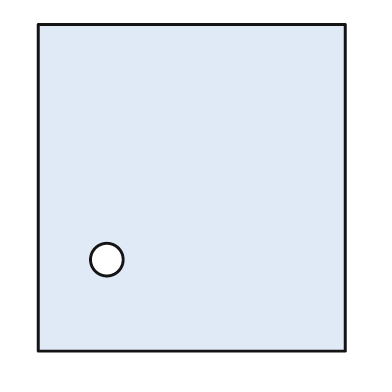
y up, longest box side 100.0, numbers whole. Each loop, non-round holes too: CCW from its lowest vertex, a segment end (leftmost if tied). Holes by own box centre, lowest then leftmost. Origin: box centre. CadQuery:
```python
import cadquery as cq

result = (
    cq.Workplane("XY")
    .moveTo(-47.0, -50.0)
    .lineTo(47.0, -50.0)
    .lineTo(47.0, 50.0)
    .lineTo(-47.0, 50.0)
    .close()
    .moveTo(-26.0, -22.0)
    .circle(5.0)
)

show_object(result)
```